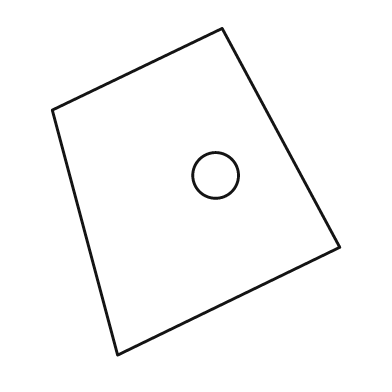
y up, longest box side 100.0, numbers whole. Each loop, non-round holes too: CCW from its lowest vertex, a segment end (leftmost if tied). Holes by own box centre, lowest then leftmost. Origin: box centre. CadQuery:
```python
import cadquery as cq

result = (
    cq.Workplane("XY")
    .moveTo(-24.0, -50.0)
    .lineTo(44.0, -17.0)
    .lineTo(8.0, 50.0)
    .lineTo(-44.0, 25.0)
    .close()
    .moveTo(6.0, 5.0)
    .circle(7.0)
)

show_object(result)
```